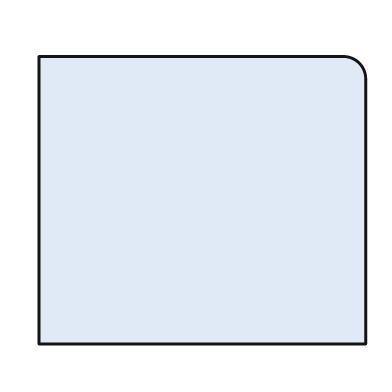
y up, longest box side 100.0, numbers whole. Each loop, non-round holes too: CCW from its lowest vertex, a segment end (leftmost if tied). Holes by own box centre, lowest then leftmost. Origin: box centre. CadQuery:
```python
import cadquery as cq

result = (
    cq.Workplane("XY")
    .moveTo(-50.0, -44.0)
    .lineTo(50.0, -44.0)
    .lineTo(50.0, 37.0)
    .threePointArc((48.0, 42.0), (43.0, 44.0))
    .lineTo(-50.0, 44.0)
    .close()
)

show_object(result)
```